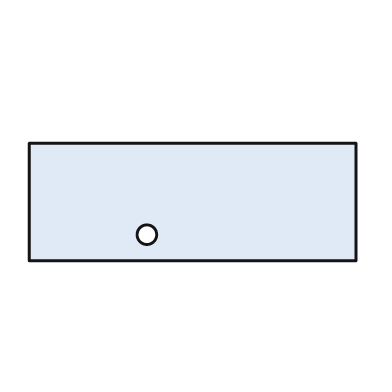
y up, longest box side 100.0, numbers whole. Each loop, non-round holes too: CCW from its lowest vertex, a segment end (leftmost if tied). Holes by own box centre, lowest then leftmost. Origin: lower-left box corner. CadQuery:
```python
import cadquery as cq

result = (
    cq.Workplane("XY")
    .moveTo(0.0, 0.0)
    .lineTo(100.0, 0.0)
    .lineTo(100.0, 36.0)
    .lineTo(0.0, 36.0)
    .close()
    .moveTo(36.0, 8.0)
    .circle(3.0)
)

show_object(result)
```